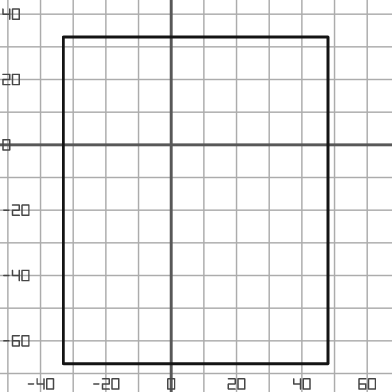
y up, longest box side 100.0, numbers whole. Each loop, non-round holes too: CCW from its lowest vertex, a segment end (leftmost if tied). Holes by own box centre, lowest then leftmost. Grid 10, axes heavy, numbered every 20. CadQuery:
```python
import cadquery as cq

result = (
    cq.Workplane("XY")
    .moveTo(-33.0, -67.0)
    .lineTo(48.0, -67.0)
    .lineTo(48.0, 33.0)
    .lineTo(-33.0, 33.0)
    .close()
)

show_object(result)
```